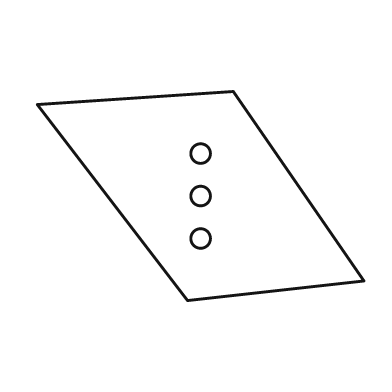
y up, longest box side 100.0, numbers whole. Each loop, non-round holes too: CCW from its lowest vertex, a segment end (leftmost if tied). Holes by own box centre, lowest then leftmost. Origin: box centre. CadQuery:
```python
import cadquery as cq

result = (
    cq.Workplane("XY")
    .moveTo(-4.0, -32.0)
    .lineTo(50.0, -26.0)
    .lineTo(10.0, 32.0)
    .lineTo(-50.0, 28.0)
    .close()
    .moveTo(0.0, -13.0)
    .circle(3.0)
    .moveTo(0.0, 0.0)
    .circle(3.0)
    .moveTo(0.0, 13.0)
    .circle(3.0)
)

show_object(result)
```